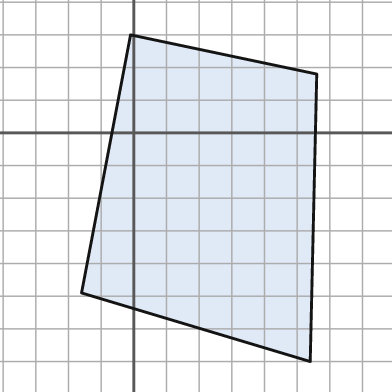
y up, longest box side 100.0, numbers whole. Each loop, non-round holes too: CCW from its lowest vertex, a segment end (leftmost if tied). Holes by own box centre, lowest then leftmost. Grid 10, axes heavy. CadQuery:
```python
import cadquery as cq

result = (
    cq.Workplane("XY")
    .moveTo(54.0, -70.0)
    .lineTo(56.0, 18.0)
    .lineTo(-1.0, 30.0)
    .lineTo(-16.0, -49.0)
    .close()
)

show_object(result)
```